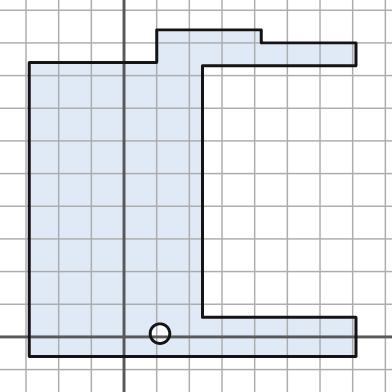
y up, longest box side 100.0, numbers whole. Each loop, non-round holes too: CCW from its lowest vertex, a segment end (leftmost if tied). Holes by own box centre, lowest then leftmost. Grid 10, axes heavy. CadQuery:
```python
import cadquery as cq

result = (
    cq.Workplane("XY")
    .moveTo(-29.0, -6.0)
    .lineTo(71.0, -6.0)
    .lineTo(71.0, 6.0)
    .lineTo(24.0, 6.0)
    .lineTo(24.0, 83.0)
    .lineTo(71.0, 83.0)
    .lineTo(71.0, 90.0)
    .lineTo(42.0, 90.0)
    .lineTo(42.0, 94.0)
    .lineTo(10.0, 94.0)
    .lineTo(10.0, 84.0)
    .lineTo(-29.0, 84.0)
    .close()
    .moveTo(11.0, 1.0)
    .circle(3.0)
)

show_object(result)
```